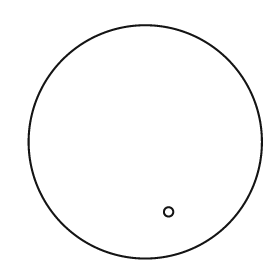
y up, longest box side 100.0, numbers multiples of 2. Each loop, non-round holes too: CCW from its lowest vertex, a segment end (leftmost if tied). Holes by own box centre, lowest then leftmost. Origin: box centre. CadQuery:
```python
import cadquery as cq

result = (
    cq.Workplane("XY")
    .moveTo(0.0, 0.0)
    .circle(50.0)
    .moveTo(10.0, -30.0)
    .circle(2.0)
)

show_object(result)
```